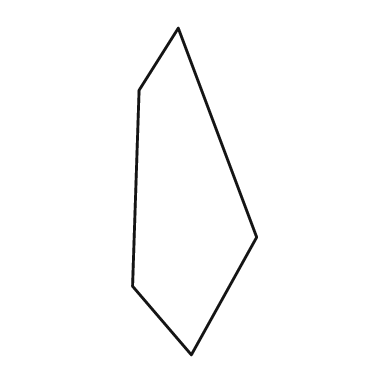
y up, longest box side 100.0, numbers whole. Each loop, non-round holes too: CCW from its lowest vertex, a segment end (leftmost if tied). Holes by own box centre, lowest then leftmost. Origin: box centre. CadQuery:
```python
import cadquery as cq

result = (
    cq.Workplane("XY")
    .moveTo(-1.0, -50.0)
    .lineTo(19.0, -14.0)
    .lineTo(-5.0, 50.0)
    .lineTo(-17.0, 31.0)
    .lineTo(-19.0, -29.0)
    .close()
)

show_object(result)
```